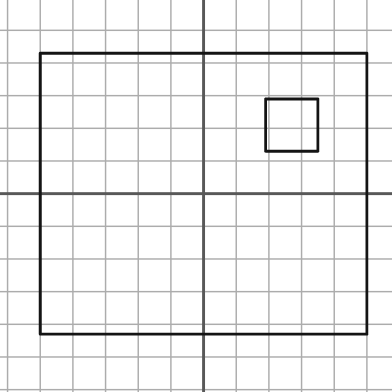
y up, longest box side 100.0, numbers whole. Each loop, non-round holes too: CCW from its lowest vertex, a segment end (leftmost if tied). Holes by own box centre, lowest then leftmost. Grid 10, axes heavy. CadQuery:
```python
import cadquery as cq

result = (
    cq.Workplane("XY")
    .moveTo(-50.0, -43.0)
    .lineTo(50.0, -43.0)
    .lineTo(50.0, 43.0)
    .lineTo(-50.0, 43.0)
    .close()
    .moveTo(19.0, 13.0)
    .lineTo(35.0, 13.0)
    .lineTo(35.0, 29.0)
    .lineTo(19.0, 29.0)
    .close()
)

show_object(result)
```